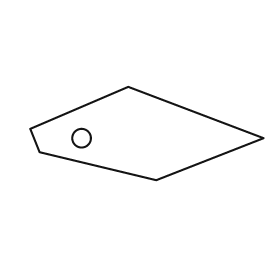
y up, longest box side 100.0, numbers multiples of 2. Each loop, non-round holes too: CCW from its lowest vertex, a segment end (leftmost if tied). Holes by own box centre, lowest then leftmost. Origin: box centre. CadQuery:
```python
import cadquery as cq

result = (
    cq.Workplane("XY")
    .moveTo(4.0, -20.0)
    .lineTo(50.0, -2.0)
    .lineTo(-8.0, 20.0)
    .lineTo(-50.0, 2.0)
    .lineTo(-46.0, -8.0)
    .close()
    .moveTo(-28.0, -2.0)
    .circle(4.0)
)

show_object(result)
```